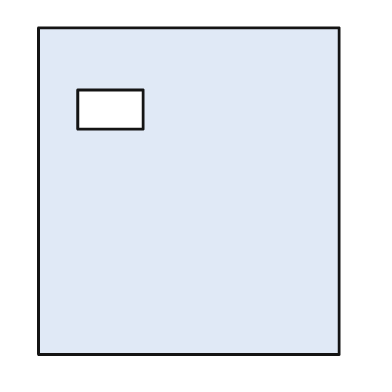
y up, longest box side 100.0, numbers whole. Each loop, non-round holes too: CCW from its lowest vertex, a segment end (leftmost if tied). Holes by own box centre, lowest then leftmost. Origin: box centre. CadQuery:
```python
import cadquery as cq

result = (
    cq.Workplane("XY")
    .moveTo(-46.0, -50.0)
    .lineTo(46.0, -50.0)
    .lineTo(46.0, 50.0)
    .lineTo(-46.0, 50.0)
    .close()
    .moveTo(-34.0, 19.0)
    .lineTo(-14.0, 19.0)
    .lineTo(-14.0, 31.0)
    .lineTo(-34.0, 31.0)
    .close()
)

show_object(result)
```